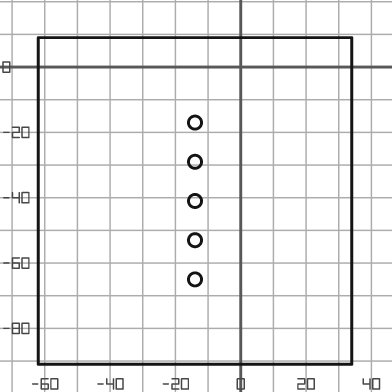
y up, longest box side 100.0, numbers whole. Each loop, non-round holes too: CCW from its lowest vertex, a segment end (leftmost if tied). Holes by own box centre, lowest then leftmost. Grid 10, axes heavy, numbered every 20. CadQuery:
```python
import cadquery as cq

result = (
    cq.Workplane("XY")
    .moveTo(-62.0, -91.0)
    .lineTo(34.0, -91.0)
    .lineTo(34.0, 9.0)
    .lineTo(-62.0, 9.0)
    .close()
    .moveTo(-14.0, -65.0)
    .circle(2.0)
    .moveTo(-14.0, -53.0)
    .circle(2.0)
    .moveTo(-14.0, -41.0)
    .circle(2.0)
    .moveTo(-14.0, -29.0)
    .circle(2.0)
    .moveTo(-14.0, -17.0)
    .circle(2.0)
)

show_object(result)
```